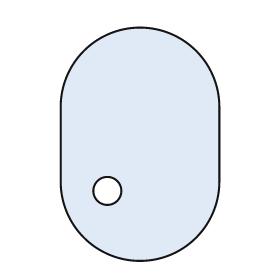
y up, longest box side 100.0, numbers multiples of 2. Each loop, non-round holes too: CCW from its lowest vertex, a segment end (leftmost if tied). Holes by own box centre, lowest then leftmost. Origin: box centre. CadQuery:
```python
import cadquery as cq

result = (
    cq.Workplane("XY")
    .moveTo(-34.0, -16.0)
    .threePointArc((0.0, -50.0), (34.0, -16.0))
    .lineTo(34.0, 16.0)
    .threePointArc((0.0, 50.0), (-34.0, 16.0))
    .close()
    .moveTo(-14.0, -20.0)
    .circle(6.0)
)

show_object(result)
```